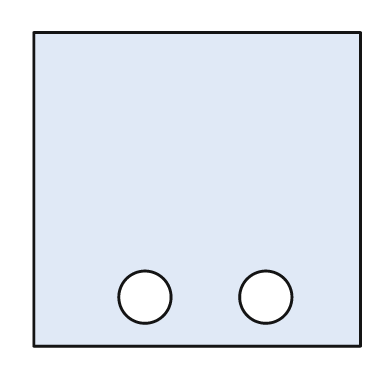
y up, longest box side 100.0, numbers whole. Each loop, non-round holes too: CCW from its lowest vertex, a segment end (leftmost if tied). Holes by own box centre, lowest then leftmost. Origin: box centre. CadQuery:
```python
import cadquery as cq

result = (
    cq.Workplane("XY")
    .moveTo(-50.0, -48.0)
    .lineTo(50.0, -48.0)
    .lineTo(50.0, 48.0)
    .lineTo(-50.0, 48.0)
    .close()
    .moveTo(-16.0, -33.0)
    .circle(8.0)
    .moveTo(21.0, -33.0)
    .circle(8.0)
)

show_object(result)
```